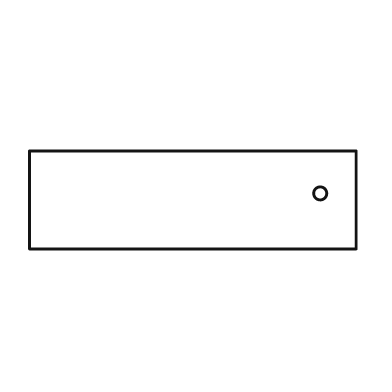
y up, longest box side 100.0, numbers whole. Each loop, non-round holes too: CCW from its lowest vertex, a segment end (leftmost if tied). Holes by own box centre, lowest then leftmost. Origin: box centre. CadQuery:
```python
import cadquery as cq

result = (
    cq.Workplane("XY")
    .moveTo(-50.0, -15.0)
    .lineTo(50.0, -15.0)
    .lineTo(50.0, 15.0)
    .lineTo(-50.0, 15.0)
    .close()
    .moveTo(39.0, 2.0)
    .circle(2.0)
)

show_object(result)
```